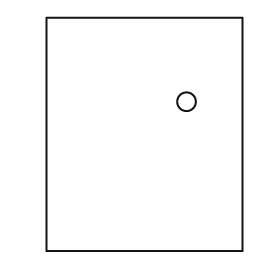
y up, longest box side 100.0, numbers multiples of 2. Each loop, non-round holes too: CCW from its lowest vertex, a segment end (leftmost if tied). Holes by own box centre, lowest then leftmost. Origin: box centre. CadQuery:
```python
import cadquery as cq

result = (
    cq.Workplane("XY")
    .moveTo(-42.0, -50.0)
    .lineTo(42.0, -50.0)
    .lineTo(42.0, 50.0)
    .lineTo(-42.0, 50.0)
    .close()
    .moveTo(18.0, 14.0)
    .circle(4.0)
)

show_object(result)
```